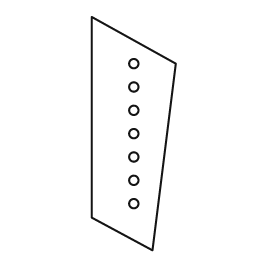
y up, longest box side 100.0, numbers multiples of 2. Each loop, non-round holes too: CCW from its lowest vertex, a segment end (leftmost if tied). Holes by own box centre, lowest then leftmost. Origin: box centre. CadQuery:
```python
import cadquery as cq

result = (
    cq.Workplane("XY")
    .moveTo(8.0, -50.0)
    .lineTo(18.0, 30.0)
    .lineTo(-18.0, 50.0)
    .lineTo(-18.0, -36.0)
    .close()
    .moveTo(0.0, -30.0)
    .circle(2.0)
    .moveTo(0.0, -20.0)
    .circle(2.0)
    .moveTo(0.0, -10.0)
    .circle(2.0)
    .moveTo(0.0, 0.0)
    .circle(2.0)
    .moveTo(0.0, 10.0)
    .circle(2.0)
    .moveTo(0.0, 20.0)
    .circle(2.0)
    .moveTo(0.0, 30.0)
    .circle(2.0)
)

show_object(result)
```